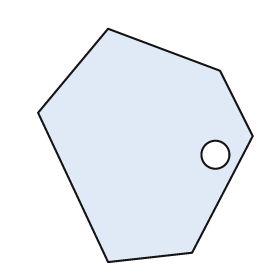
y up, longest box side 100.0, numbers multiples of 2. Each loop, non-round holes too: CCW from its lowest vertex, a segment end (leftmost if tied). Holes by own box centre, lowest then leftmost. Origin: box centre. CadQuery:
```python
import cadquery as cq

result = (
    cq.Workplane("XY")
    .moveTo(-16.0, -50.0)
    .lineTo(20.0, -46.0)
    .lineTo(46.0, 4.0)
    .lineTo(32.0, 32.0)
    .lineTo(-16.0, 50.0)
    .lineTo(-46.0, 14.0)
    .close()
    .moveTo(30.0, -4.0)
    .circle(6.0)
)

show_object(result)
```